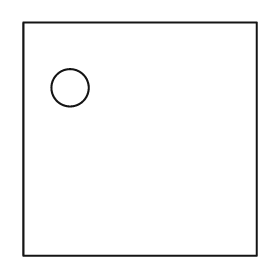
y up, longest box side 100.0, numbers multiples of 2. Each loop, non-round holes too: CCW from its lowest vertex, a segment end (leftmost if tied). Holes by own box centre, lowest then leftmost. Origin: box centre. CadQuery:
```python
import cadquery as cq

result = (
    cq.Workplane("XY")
    .moveTo(-50.0, -50.0)
    .lineTo(50.0, -50.0)
    .lineTo(50.0, 50.0)
    .lineTo(-50.0, 50.0)
    .close()
    .moveTo(-30.0, 22.0)
    .circle(8.0)
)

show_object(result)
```